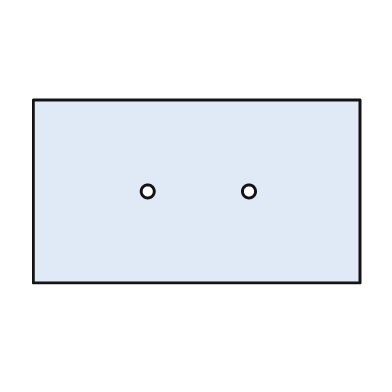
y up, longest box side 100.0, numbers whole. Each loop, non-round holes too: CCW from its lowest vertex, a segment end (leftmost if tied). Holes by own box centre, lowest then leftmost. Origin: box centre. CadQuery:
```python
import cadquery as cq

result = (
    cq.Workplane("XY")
    .moveTo(-50.0, -28.0)
    .lineTo(50.0, -28.0)
    .lineTo(50.0, 28.0)
    .lineTo(-50.0, 28.0)
    .close()
    .moveTo(-15.0, 0.0)
    .circle(2.0)
    .moveTo(16.0, 0.0)
    .circle(2.0)
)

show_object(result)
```